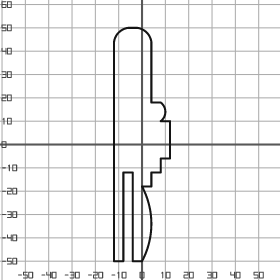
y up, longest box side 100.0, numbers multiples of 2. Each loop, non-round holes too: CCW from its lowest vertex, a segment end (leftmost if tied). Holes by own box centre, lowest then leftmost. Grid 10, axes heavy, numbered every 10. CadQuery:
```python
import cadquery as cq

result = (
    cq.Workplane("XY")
    .moveTo(-12.0, -50.0)
    .lineTo(-8.0, -50.0)
    .lineTo(-8.0, -12.0)
    .lineTo(-4.0, -12.0)
    .lineTo(-4.0, -50.0)
    .lineTo(0.0, -50.0)
    .threePointArc((4.0, -34.0), (0.0, -18.0))
    .lineTo(4.0, -18.0)
    .lineTo(4.0, -12.0)
    .lineTo(8.0, -12.0)
    .lineTo(8.0, -6.0)
    .lineTo(12.0, -6.0)
    .lineTo(12.0, 10.0)
    .lineTo(8.0, 10.0)
    .threePointArc((10.0, 14.0), (8.0, 18.0))
    .lineTo(4.0, 18.0)
    .lineTo(4.0, 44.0)
    .threePointArc((2.0, 48.0), (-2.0, 50.0))
    .lineTo(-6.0, 50.0)
    .threePointArc((-10.0, 48.0), (-12.0, 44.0))
    .close()
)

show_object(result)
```